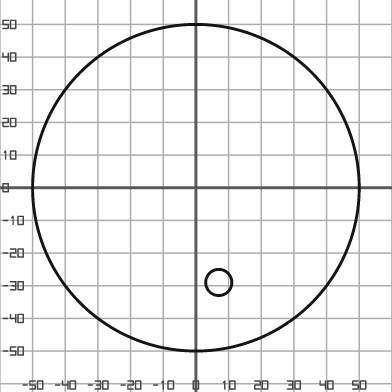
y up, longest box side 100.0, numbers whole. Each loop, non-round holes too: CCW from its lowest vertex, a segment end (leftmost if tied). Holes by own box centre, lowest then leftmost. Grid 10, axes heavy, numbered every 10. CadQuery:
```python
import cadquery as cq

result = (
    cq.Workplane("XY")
    .moveTo(0.0, 0.0)
    .circle(50.0)
    .moveTo(7.0, -29.0)
    .circle(4.0)
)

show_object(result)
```